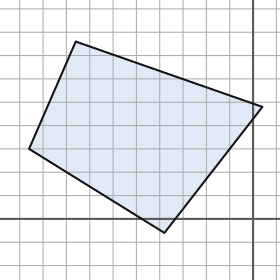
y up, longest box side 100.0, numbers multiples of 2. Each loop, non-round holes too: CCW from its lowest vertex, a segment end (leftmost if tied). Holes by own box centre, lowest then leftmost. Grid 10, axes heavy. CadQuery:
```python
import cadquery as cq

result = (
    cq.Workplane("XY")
    .moveTo(-38.0, -6.0)
    .lineTo(4.0, 48.0)
    .lineTo(-76.0, 76.0)
    .lineTo(-96.0, 30.0)
    .close()
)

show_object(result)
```